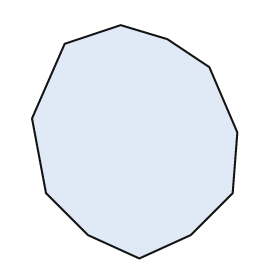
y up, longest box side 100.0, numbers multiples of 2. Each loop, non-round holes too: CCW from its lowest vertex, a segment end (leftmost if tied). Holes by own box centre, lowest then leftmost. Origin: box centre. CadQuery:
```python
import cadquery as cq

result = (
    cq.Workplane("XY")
    .moveTo(2.0, -50.0)
    .lineTo(24.0, -40.0)
    .lineTo(42.0, -22.0)
    .lineTo(44.0, 4.0)
    .lineTo(32.0, 32.0)
    .lineTo(14.0, 44.0)
    .lineTo(-6.0, 50.0)
    .lineTo(-30.0, 42.0)
    .lineTo(-44.0, 10.0)
    .lineTo(-38.0, -22.0)
    .lineTo(-20.0, -40.0)
    .close()
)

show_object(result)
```